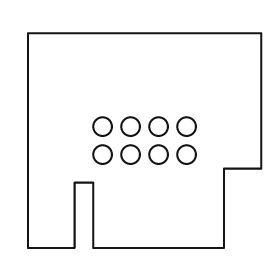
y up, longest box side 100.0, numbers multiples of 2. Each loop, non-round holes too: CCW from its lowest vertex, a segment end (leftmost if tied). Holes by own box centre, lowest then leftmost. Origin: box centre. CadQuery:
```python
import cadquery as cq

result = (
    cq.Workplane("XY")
    .moveTo(-50.0, -46.0)
    .lineTo(-30.0, -46.0)
    .lineTo(-30.0, -18.0)
    .lineTo(-22.0, -18.0)
    .lineTo(-22.0, -46.0)
    .lineTo(34.0, -46.0)
    .lineTo(34.0, -12.0)
    .lineTo(50.0, -12.0)
    .lineTo(50.0, 46.0)
    .lineTo(-50.0, 46.0)
    .close()
    .moveTo(-18.0, -6.0)
    .circle(4.0)
    .moveTo(-6.0, -6.0)
    .circle(4.0)
    .moveTo(6.0, -6.0)
    .circle(4.0)
    .moveTo(18.0, -6.0)
    .circle(4.0)
    .moveTo(-18.0, 6.0)
    .circle(4.0)
    .moveTo(-6.0, 6.0)
    .circle(4.0)
    .moveTo(6.0, 6.0)
    .circle(4.0)
    .moveTo(18.0, 6.0)
    .circle(4.0)
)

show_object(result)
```